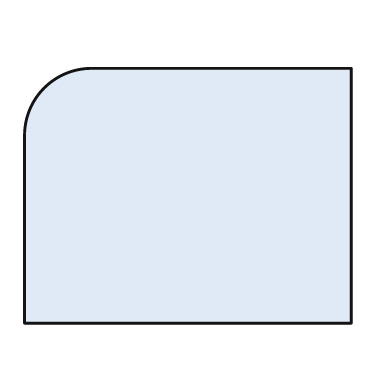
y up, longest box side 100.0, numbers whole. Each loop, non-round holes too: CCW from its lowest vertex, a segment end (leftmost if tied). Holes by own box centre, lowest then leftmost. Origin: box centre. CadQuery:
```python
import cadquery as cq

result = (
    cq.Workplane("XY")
    .moveTo(-50.0, -39.0)
    .lineTo(50.0, -39.0)
    .lineTo(50.0, 39.0)
    .lineTo(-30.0, 39.0)
    .threePointArc((-44.0, 33.0), (-50.0, 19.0))
    .close()
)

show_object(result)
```